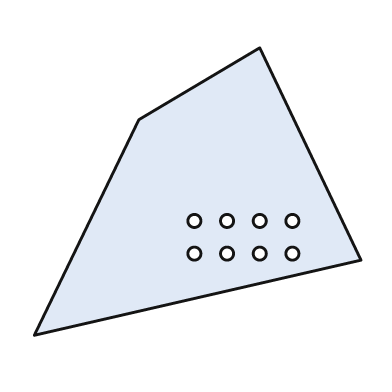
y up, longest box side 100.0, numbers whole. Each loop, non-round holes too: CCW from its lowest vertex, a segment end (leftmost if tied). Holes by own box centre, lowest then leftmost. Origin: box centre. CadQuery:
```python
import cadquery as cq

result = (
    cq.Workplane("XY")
    .moveTo(-50.0, -44.0)
    .lineTo(50.0, -21.0)
    .lineTo(19.0, 44.0)
    .lineTo(-18.0, 22.0)
    .close()
    .moveTo(-1.0, -19.0)
    .circle(2.0)
    .moveTo(9.0, -19.0)
    .circle(2.0)
    .moveTo(19.0, -19.0)
    .circle(2.0)
    .moveTo(29.0, -19.0)
    .circle(2.0)
    .moveTo(-1.0, -9.0)
    .circle(2.0)
    .moveTo(9.0, -9.0)
    .circle(2.0)
    .moveTo(19.0, -9.0)
    .circle(2.0)
    .moveTo(29.0, -9.0)
    .circle(2.0)
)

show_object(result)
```